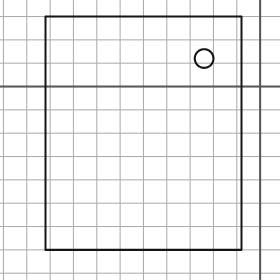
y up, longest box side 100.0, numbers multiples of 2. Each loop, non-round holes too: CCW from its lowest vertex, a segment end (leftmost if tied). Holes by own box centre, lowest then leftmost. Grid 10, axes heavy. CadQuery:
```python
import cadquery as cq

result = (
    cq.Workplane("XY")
    .moveTo(-92.0, -70.0)
    .lineTo(-8.0, -70.0)
    .lineTo(-8.0, 30.0)
    .lineTo(-92.0, 30.0)
    .close()
    .moveTo(-24.0, 12.0)
    .circle(4.0)
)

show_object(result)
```